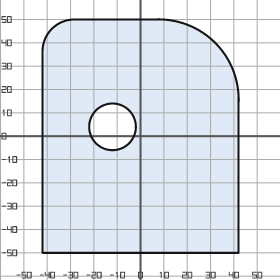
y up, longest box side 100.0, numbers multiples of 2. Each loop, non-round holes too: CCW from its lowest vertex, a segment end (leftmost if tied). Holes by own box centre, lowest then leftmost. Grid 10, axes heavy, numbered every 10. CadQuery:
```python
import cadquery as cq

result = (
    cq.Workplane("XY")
    .moveTo(-42.0, -50.0)
    .lineTo(42.0, -50.0)
    .lineTo(42.0, 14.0)
    .threePointArc((32.0, 40.0), (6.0, 50.0))
    .lineTo(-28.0, 50.0)
    .threePointArc((-38.0, 46.0), (-42.0, 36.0))
    .close()
    .moveTo(-12.0, 4.0)
    .circle(10.0)
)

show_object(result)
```